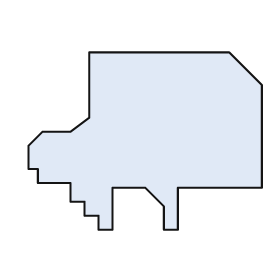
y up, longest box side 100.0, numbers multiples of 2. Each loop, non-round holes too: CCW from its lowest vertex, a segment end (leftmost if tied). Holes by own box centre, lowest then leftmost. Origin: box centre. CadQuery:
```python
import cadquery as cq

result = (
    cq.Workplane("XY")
    .moveTo(-20.0, -38.0)
    .lineTo(-14.0, -38.0)
    .lineTo(-14.0, -20.0)
    .lineTo(0.0, -20.0)
    .lineTo(8.0, -28.0)
    .lineTo(8.0, -38.0)
    .lineTo(14.0, -38.0)
    .lineTo(14.0, -20.0)
    .lineTo(50.0, -20.0)
    .lineTo(50.0, 24.0)
    .lineTo(36.0, 38.0)
    .lineTo(-24.0, 38.0)
    .lineTo(-24.0, 10.0)
    .lineTo(-32.0, 4.0)
    .lineTo(-44.0, 4.0)
    .lineTo(-50.0, -2.0)
    .lineTo(-50.0, -12.0)
    .lineTo(-46.0, -12.0)
    .lineTo(-46.0, -18.0)
    .lineTo(-32.0, -18.0)
    .lineTo(-32.0, -26.0)
    .lineTo(-26.0, -26.0)
    .lineTo(-26.0, -32.0)
    .lineTo(-20.0, -32.0)
    .close()
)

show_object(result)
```